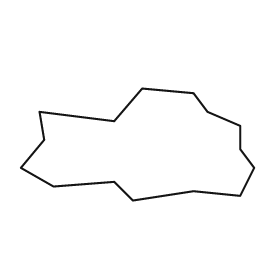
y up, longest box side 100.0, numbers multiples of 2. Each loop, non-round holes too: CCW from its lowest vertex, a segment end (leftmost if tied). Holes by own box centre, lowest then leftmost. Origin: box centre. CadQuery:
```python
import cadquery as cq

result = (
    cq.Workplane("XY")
    .moveTo(-2.0, -24.0)
    .lineTo(24.0, -20.0)
    .lineTo(44.0, -22.0)
    .lineTo(50.0, -10.0)
    .lineTo(44.0, -2.0)
    .lineTo(44.0, 8.0)
    .lineTo(30.0, 14.0)
    .lineTo(24.0, 22.0)
    .lineTo(2.0, 24.0)
    .lineTo(-10.0, 10.0)
    .lineTo(-42.0, 14.0)
    .lineTo(-40.0, 2.0)
    .lineTo(-50.0, -10.0)
    .lineTo(-36.0, -18.0)
    .lineTo(-10.0, -16.0)
    .close()
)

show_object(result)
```